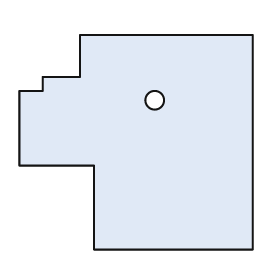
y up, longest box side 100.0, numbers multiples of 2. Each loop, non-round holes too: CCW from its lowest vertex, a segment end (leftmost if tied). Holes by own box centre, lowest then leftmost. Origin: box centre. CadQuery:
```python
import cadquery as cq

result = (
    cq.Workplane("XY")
    .moveTo(-18.0, -46.0)
    .lineTo(50.0, -46.0)
    .lineTo(50.0, 46.0)
    .lineTo(-24.0, 46.0)
    .lineTo(-24.0, 28.0)
    .lineTo(-40.0, 28.0)
    .lineTo(-40.0, 22.0)
    .lineTo(-50.0, 22.0)
    .lineTo(-50.0, -10.0)
    .lineTo(-18.0, -10.0)
    .close()
    .moveTo(8.0, 18.0)
    .circle(4.0)
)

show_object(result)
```